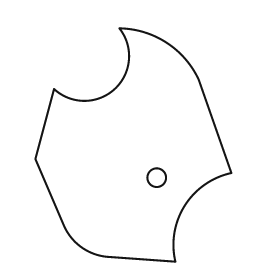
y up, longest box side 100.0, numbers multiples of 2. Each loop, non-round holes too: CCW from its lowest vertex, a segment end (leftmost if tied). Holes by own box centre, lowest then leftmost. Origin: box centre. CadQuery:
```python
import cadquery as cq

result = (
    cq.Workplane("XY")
    .moveTo(18.0, -50.0)
    .threePointArc((22.0, -26.0), (42.0, -12.0))
    .lineTo(28.0, 28.0)
    .threePointArc((14.0, 44.0), (-6.0, 50.0))
    .threePointArc((-8.0, 24.0), (-34.0, 24.0))
    .lineTo(-42.0, -6.0)
    .lineTo(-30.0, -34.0)
    .threePointArc((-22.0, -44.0), (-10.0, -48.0))
    .close()
    .moveTo(10.0, -14.0)
    .circle(4.0)
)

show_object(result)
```